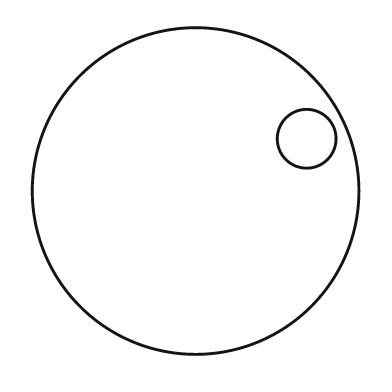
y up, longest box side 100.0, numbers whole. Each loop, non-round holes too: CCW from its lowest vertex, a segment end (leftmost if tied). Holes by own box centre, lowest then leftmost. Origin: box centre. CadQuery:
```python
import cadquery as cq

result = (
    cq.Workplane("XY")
    .moveTo(0.0, 0.0)
    .circle(50.0)
    .moveTo(34.0, 16.0)
    .circle(9.0)
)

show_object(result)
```